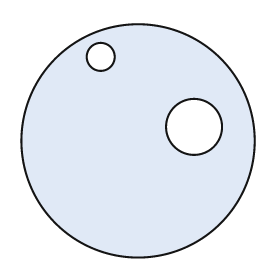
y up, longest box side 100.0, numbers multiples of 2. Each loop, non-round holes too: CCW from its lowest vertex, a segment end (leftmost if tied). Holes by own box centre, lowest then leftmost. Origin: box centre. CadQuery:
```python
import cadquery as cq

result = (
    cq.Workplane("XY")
    .moveTo(0.0, 0.0)
    .circle(50.0)
    .moveTo(24.0, 6.0)
    .circle(12.0)
    .moveTo(-16.0, 36.0)
    .circle(6.0)
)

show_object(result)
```